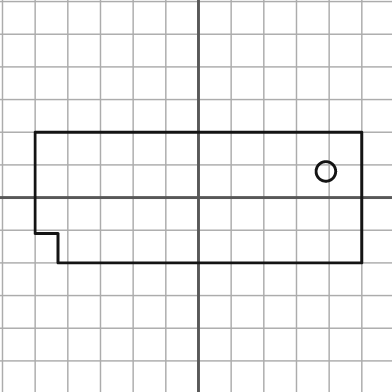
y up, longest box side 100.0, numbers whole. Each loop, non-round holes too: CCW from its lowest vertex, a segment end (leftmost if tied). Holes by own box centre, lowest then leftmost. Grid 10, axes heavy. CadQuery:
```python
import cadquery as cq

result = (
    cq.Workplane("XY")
    .moveTo(-43.0, -20.0)
    .lineTo(50.0, -20.0)
    .lineTo(50.0, 20.0)
    .lineTo(-50.0, 20.0)
    .lineTo(-50.0, -11.0)
    .lineTo(-43.0, -11.0)
    .close()
    .moveTo(39.0, 8.0)
    .circle(3.0)
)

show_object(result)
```